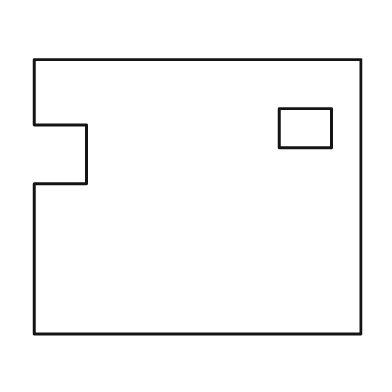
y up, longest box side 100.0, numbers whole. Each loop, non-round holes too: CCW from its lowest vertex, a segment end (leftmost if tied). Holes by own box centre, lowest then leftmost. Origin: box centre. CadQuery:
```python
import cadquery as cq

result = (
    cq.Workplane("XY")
    .moveTo(-50.0, -42.0)
    .lineTo(50.0, -42.0)
    .lineTo(50.0, 42.0)
    .lineTo(-50.0, 42.0)
    .lineTo(-50.0, 22.0)
    .lineTo(-34.0, 22.0)
    .lineTo(-34.0, 4.0)
    .lineTo(-50.0, 4.0)
    .close()
    .moveTo(25.0, 15.0)
    .lineTo(41.0, 15.0)
    .lineTo(41.0, 27.0)
    .lineTo(25.0, 27.0)
    .close()
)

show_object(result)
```